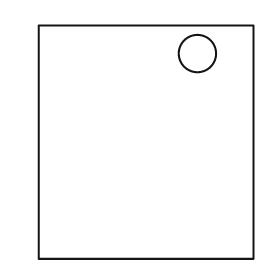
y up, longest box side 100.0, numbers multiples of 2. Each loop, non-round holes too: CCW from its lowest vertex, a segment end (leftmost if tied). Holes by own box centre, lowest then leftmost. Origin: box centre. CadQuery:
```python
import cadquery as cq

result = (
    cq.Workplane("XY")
    .moveTo(-46.0, -50.0)
    .lineTo(46.0, -50.0)
    .lineTo(46.0, 50.0)
    .lineTo(-46.0, 50.0)
    .close()
    .moveTo(22.0, 38.0)
    .circle(8.0)
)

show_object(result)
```